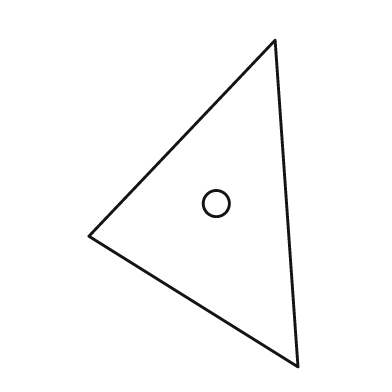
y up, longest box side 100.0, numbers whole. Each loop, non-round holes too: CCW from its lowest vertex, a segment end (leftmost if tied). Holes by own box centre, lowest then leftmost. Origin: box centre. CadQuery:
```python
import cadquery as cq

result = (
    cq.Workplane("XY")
    .moveTo(32.0, -50.0)
    .lineTo(25.0, 50.0)
    .lineTo(-32.0, -10.0)
    .close()
    .moveTo(7.0, 0.0)
    .circle(4.0)
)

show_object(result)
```